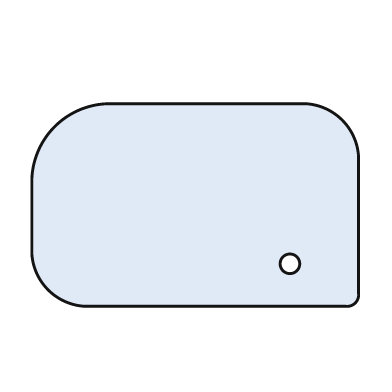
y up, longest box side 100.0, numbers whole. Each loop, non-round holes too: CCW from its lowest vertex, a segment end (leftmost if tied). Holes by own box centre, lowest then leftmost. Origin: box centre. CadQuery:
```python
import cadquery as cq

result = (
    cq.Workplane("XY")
    .moveTo(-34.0, -31.0)
    .lineTo(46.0, -31.0)
    .threePointArc((49.0, -30.0), (50.0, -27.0))
    .lineTo(50.0, 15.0)
    .threePointArc((45.0, 26.0), (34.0, 31.0))
    .lineTo(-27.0, 31.0)
    .threePointArc((-43.0, 24.0), (-50.0, 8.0))
    .lineTo(-50.0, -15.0)
    .threePointArc((-45.0, -26.0), (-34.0, -31.0))
    .close()
    .moveTo(29.0, -18.0)
    .circle(3.0)
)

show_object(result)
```